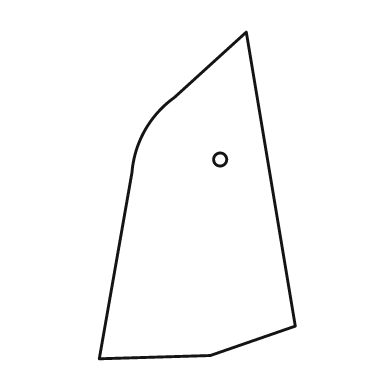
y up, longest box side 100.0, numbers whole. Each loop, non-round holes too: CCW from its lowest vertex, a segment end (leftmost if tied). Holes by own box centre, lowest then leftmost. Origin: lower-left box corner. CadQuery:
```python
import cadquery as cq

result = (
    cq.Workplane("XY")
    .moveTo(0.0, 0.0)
    .lineTo(34.0, 1.0)
    .lineTo(60.0, 10.0)
    .lineTo(45.0, 100.0)
    .lineTo(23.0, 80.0)
    .threePointArc((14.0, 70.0), (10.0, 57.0))
    .close()
    .moveTo(37.0, 61.0)
    .circle(2.0)
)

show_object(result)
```